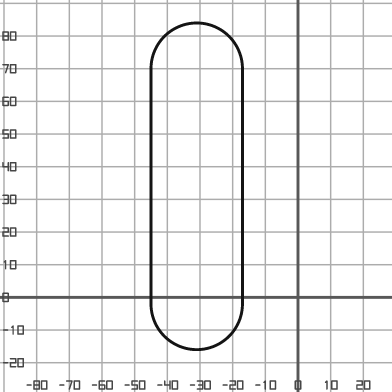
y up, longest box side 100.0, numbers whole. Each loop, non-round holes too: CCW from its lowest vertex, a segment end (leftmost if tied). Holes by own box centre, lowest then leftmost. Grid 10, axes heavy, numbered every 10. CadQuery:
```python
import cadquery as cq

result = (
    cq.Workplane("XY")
    .moveTo(-45.0, -2.0)
    .threePointArc((-31.0, -16.0), (-17.0, -2.0))
    .lineTo(-17.0, 70.0)
    .threePointArc((-31.0, 84.0), (-45.0, 70.0))
    .close()
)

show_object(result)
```